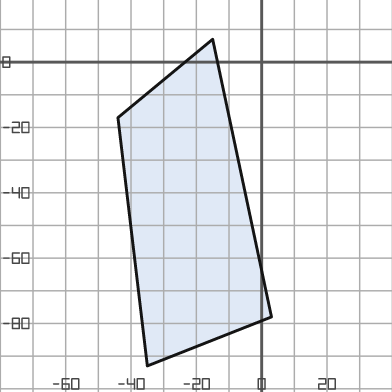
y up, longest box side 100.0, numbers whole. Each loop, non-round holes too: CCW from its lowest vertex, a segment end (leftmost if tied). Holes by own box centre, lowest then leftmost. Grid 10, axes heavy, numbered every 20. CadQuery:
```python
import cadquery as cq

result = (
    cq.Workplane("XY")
    .moveTo(-35.0, -93.0)
    .lineTo(3.0, -78.0)
    .lineTo(-15.0, 7.0)
    .lineTo(-44.0, -17.0)
    .close()
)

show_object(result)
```